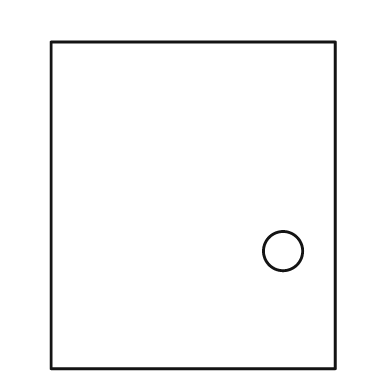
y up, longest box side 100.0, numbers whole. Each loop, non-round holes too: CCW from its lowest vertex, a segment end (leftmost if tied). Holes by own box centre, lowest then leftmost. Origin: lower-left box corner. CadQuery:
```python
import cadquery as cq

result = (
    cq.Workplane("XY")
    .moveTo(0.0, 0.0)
    .lineTo(87.0, 0.0)
    .lineTo(87.0, 100.0)
    .lineTo(0.0, 100.0)
    .close()
    .moveTo(71.0, 36.0)
    .circle(6.0)
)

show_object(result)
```